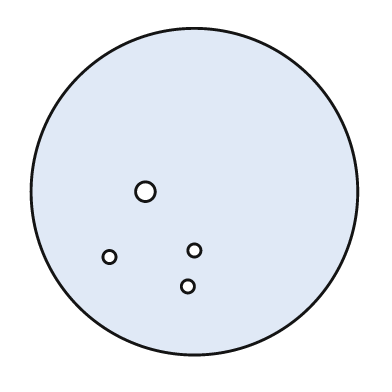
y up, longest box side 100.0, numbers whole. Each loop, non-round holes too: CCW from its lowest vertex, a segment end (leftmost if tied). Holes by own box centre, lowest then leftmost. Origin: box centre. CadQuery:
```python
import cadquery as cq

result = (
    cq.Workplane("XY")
    .moveTo(0.0, 0.0)
    .circle(50.0)
    .moveTo(-2.0, -29.0)
    .circle(2.0)
    .moveTo(-26.0, -20.0)
    .circle(2.0)
    .moveTo(0.0, -18.0)
    .circle(2.0)
    .moveTo(-15.0, 0.0)
    .circle(3.0)
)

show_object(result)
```